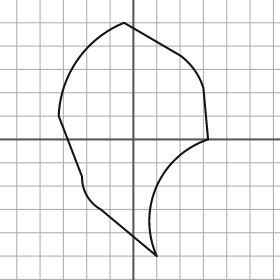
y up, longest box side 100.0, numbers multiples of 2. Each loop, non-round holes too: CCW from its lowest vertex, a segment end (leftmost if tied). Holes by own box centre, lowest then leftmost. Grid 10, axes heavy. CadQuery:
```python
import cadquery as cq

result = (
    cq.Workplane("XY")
    .moveTo(10.0, -50.0)
    .threePointArc((10.0, -20.0), (32.0, 0.0))
    .lineTo(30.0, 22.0)
    .threePointArc((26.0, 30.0), (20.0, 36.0))
    .lineTo(-4.0, 50.0)
    .threePointArc((-24.0, 34.0), (-32.0, 10.0))
    .lineTo(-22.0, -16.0)
    .threePointArc((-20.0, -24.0), (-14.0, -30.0))
    .close()
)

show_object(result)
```